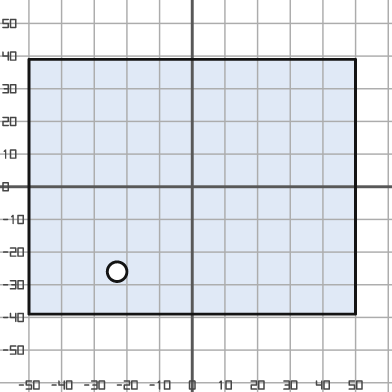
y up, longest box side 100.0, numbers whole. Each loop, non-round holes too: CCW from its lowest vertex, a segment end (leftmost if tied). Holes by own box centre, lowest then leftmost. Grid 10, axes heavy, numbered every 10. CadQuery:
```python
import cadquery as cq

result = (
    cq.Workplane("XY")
    .moveTo(-50.0, -39.0)
    .lineTo(50.0, -39.0)
    .lineTo(50.0, 39.0)
    .lineTo(-50.0, 39.0)
    .close()
    .moveTo(-23.0, -26.0)
    .circle(3.0)
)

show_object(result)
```